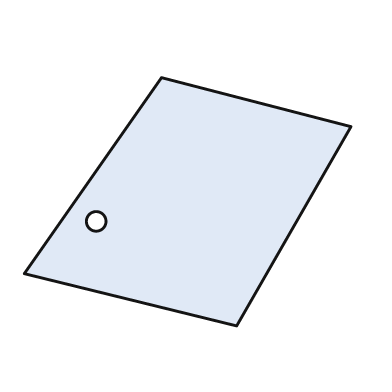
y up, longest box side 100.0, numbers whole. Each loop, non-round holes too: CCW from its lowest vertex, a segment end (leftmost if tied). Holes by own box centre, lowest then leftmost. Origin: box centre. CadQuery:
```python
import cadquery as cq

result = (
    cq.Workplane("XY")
    .moveTo(15.0, -38.0)
    .lineTo(50.0, 23.0)
    .lineTo(-8.0, 38.0)
    .lineTo(-50.0, -22.0)
    .close()
    .moveTo(-28.0, -6.0)
    .circle(3.0)
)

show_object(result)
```